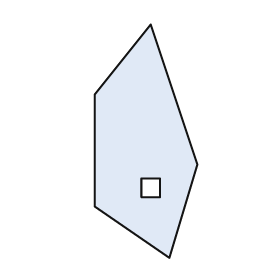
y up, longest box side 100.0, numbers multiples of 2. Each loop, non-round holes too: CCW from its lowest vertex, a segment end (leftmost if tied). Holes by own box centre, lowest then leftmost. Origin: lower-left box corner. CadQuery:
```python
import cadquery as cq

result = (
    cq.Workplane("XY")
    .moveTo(32.0, 0.0)
    .lineTo(44.0, 40.0)
    .lineTo(24.0, 100.0)
    .lineTo(0.0, 70.0)
    .lineTo(0.0, 22.0)
    .close()
    .moveTo(20.0, 26.0)
    .lineTo(28.0, 26.0)
    .lineTo(28.0, 34.0)
    .lineTo(20.0, 34.0)
    .close()
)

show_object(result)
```